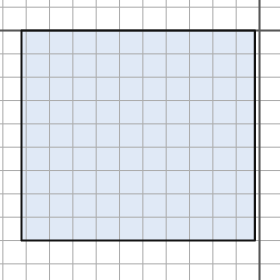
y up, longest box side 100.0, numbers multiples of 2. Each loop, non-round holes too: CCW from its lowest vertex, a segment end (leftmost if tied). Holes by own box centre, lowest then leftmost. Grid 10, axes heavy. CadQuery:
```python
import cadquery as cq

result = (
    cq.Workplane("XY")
    .moveTo(-102.0, -90.0)
    .lineTo(-2.0, -90.0)
    .lineTo(-2.0, 0.0)
    .lineTo(-102.0, 0.0)
    .close()
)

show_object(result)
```